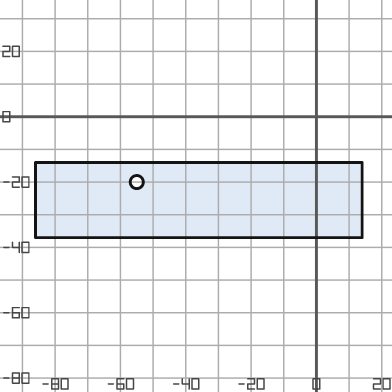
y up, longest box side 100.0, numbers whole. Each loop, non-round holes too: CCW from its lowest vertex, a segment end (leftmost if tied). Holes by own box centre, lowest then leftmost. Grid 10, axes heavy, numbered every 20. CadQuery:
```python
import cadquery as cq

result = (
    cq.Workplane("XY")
    .moveTo(-86.0, -37.0)
    .lineTo(14.0, -37.0)
    .lineTo(14.0, -14.0)
    .lineTo(-86.0, -14.0)
    .close()
    .moveTo(-55.0, -20.0)
    .circle(2.0)
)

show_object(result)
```